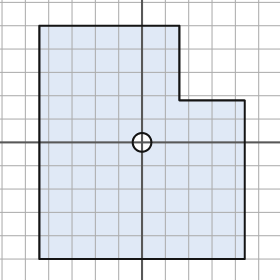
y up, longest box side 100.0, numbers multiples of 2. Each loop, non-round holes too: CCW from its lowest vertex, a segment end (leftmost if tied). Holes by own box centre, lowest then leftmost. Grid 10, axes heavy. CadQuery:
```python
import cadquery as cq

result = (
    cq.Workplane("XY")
    .moveTo(-44.0, -50.0)
    .lineTo(44.0, -50.0)
    .lineTo(44.0, 18.0)
    .lineTo(16.0, 18.0)
    .lineTo(16.0, 50.0)
    .lineTo(-44.0, 50.0)
    .close()
    .moveTo(0.0, 0.0)
    .circle(4.0)
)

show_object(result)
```